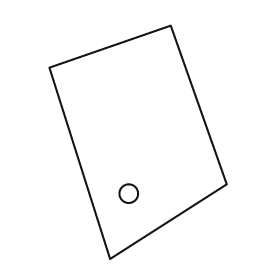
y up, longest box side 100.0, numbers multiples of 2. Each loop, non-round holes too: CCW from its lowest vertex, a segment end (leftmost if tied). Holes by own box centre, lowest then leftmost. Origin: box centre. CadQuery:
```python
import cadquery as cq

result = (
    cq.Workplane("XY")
    .moveTo(-12.0, -50.0)
    .lineTo(38.0, -18.0)
    .lineTo(14.0, 50.0)
    .lineTo(-38.0, 32.0)
    .close()
    .moveTo(-4.0, -22.0)
    .circle(4.0)
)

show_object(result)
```